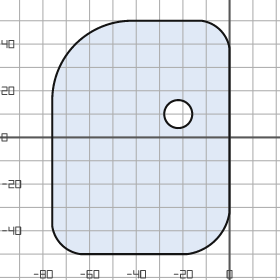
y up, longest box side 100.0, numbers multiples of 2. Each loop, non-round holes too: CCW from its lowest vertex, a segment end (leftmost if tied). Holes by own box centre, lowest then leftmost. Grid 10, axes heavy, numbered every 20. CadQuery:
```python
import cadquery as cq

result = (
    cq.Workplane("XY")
    .moveTo(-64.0, -50.0)
    .lineTo(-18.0, -50.0)
    .threePointArc((-6.0, -44.0), (0.0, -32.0))
    .lineTo(0.0, 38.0)
    .threePointArc((-4.0, 46.0), (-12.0, 50.0))
    .lineTo(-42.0, 50.0)
    .threePointArc((-66.0, 40.0), (-76.0, 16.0))
    .lineTo(-76.0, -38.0)
    .threePointArc((-72.0, -46.0), (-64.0, -50.0))
    .close()
    .moveTo(-22.0, 10.0)
    .circle(6.0)
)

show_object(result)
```